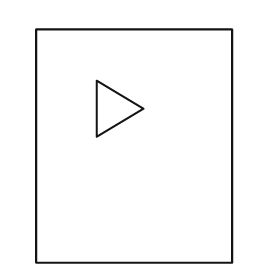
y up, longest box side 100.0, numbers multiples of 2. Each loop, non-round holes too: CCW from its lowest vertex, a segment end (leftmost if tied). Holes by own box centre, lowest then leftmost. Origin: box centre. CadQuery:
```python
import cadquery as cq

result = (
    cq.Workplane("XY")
    .moveTo(-42.0, -50.0)
    .lineTo(42.0, -50.0)
    .lineTo(42.0, 50.0)
    .lineTo(-42.0, 50.0)
    .close()
    .moveTo(-16.0, 4.0)
    .lineTo(4.0, 16.0)
    .lineTo(-16.0, 28.0)
    .close()
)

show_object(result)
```